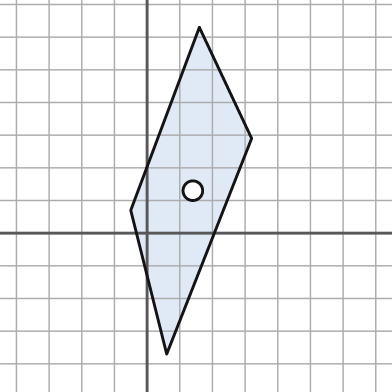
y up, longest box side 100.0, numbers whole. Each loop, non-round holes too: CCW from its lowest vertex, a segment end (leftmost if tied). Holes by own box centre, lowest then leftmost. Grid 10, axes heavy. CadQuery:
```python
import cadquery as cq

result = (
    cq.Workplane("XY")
    .moveTo(6.0, -37.0)
    .lineTo(32.0, 29.0)
    .lineTo(16.0, 63.0)
    .lineTo(-5.0, 7.0)
    .close()
    .moveTo(14.0, 13.0)
    .circle(3.0)
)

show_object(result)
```